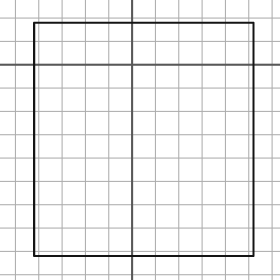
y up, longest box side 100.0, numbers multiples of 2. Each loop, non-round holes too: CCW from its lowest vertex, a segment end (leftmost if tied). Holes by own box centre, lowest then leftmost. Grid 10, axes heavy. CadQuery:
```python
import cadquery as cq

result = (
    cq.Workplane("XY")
    .moveTo(-42.0, -82.0)
    .lineTo(52.0, -82.0)
    .lineTo(52.0, 18.0)
    .lineTo(-42.0, 18.0)
    .close()
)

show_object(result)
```